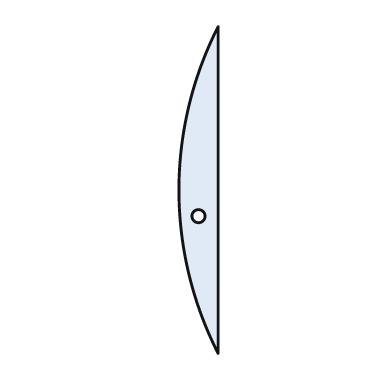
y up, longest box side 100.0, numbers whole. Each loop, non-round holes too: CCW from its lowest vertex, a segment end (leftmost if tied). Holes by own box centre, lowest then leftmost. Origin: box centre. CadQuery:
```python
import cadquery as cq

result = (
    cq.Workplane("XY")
    .moveTo(6.0, -50.0)
    .lineTo(6.0, 50.0)
    .threePointArc((-6.0, 0.0), (6.0, -50.0))
    .close()
    .moveTo(0.0, -8.0)
    .circle(2.0)
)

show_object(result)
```